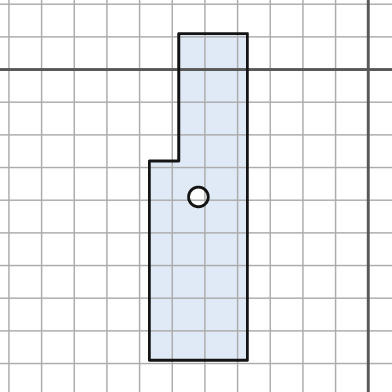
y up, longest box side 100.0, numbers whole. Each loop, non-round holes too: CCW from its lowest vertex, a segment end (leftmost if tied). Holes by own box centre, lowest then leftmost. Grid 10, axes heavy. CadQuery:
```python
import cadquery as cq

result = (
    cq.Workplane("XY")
    .moveTo(-67.0, -89.0)
    .lineTo(-37.0, -89.0)
    .lineTo(-37.0, 11.0)
    .lineTo(-58.0, 11.0)
    .lineTo(-58.0, -28.0)
    .lineTo(-67.0, -28.0)
    .close()
    .moveTo(-52.0, -39.0)
    .circle(3.0)
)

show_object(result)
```